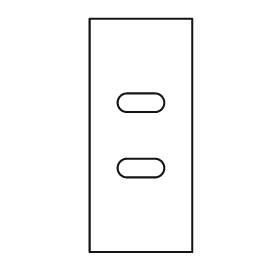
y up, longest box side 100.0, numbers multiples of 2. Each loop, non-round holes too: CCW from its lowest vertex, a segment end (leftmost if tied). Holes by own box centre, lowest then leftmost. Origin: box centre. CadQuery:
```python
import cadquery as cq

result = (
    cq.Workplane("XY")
    .moveTo(-22.0, -50.0)
    .lineTo(22.0, -50.0)
    .lineTo(22.0, 50.0)
    .lineTo(-22.0, 50.0)
    .close()
    .moveTo(-6.0, -18.0)
    .lineTo(6.0, -18.0)
    .threePointArc((10.0, -14.0), (6.0, -10.0))
    .lineTo(-6.0, -10.0)
    .threePointArc((-10.0, -14.0), (-6.0, -18.0))
    .close()
    .moveTo(-6.0, 10.0)
    .lineTo(6.0, 10.0)
    .threePointArc((10.0, 14.0), (6.0, 18.0))
    .lineTo(-6.0, 18.0)
    .threePointArc((-10.0, 14.0), (-6.0, 10.0))
    .close()
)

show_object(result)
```